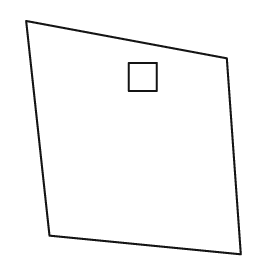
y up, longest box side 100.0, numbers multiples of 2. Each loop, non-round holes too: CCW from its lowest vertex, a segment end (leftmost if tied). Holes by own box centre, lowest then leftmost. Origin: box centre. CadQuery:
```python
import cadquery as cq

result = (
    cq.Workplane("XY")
    .moveTo(46.0, -50.0)
    .lineTo(40.0, 34.0)
    .lineTo(-46.0, 50.0)
    .lineTo(-36.0, -42.0)
    .close()
    .moveTo(-2.0, 20.0)
    .lineTo(10.0, 20.0)
    .lineTo(10.0, 32.0)
    .lineTo(-2.0, 32.0)
    .close()
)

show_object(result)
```